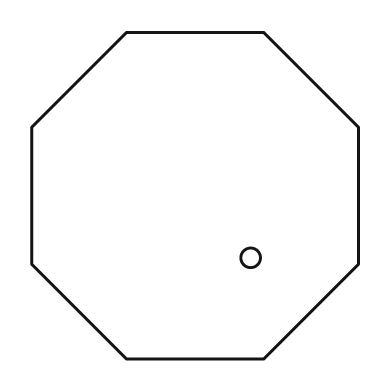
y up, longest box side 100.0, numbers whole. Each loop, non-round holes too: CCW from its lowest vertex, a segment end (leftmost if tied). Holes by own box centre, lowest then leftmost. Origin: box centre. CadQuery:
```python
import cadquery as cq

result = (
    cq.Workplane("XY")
    .moveTo(-21.0, -50.0)
    .lineTo(21.0, -50.0)
    .lineTo(50.0, -21.0)
    .lineTo(50.0, 21.0)
    .lineTo(21.0, 50.0)
    .lineTo(-21.0, 50.0)
    .lineTo(-50.0, 21.0)
    .lineTo(-50.0, -21.0)
    .close()
    .moveTo(17.0, -19.0)
    .circle(3.0)
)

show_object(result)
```